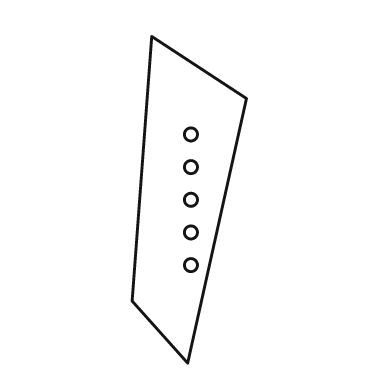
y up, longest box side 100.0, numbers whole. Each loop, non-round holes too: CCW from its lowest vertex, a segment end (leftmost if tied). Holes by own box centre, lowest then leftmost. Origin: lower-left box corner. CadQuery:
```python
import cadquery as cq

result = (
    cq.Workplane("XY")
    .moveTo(17.0, 0.0)
    .lineTo(35.0, 81.0)
    .lineTo(6.0, 100.0)
    .lineTo(0.0, 19.0)
    .close()
    .moveTo(18.0, 30.0)
    .circle(2.0)
    .moveTo(18.0, 40.0)
    .circle(2.0)
    .moveTo(18.0, 50.0)
    .circle(2.0)
    .moveTo(18.0, 60.0)
    .circle(2.0)
    .moveTo(18.0, 70.0)
    .circle(2.0)
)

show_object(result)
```